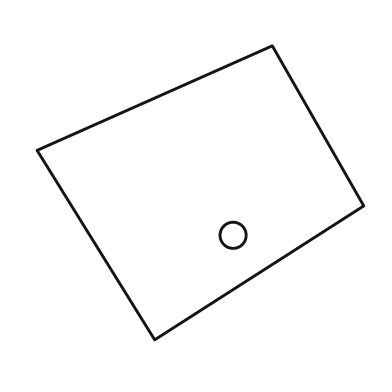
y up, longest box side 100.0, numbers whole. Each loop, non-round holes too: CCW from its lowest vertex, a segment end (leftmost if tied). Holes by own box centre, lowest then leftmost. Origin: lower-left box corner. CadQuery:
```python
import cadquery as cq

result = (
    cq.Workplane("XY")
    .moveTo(36.0, 0.0)
    .lineTo(100.0, 41.0)
    .lineTo(72.0, 90.0)
    .lineTo(0.0, 58.0)
    .close()
    .moveTo(60.0, 32.0)
    .circle(4.0)
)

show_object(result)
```